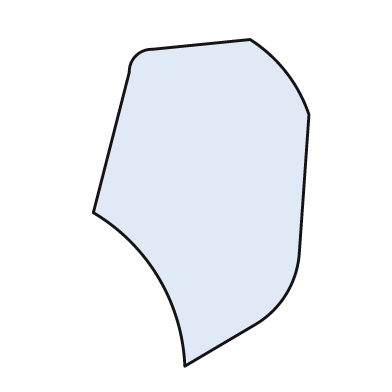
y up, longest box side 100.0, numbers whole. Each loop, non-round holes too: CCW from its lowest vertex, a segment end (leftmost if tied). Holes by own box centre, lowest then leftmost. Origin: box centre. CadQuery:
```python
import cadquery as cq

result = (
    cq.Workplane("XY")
    .moveTo(-5.0, -50.0)
    .lineTo(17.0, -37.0)
    .threePointArc((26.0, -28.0), (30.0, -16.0))
    .lineTo(33.0, 27.0)
    .threePointArc((26.0, 40.0), (15.0, 50.0))
    .lineTo(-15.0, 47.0)
    .threePointArc((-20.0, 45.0), (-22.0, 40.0))
    .lineTo(-33.0, -3.0)
    .threePointArc((-13.0, -23.0), (-5.0, -50.0))
    .close()
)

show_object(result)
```